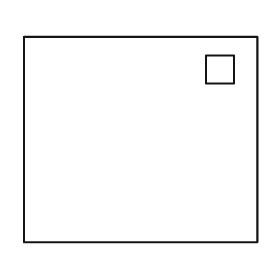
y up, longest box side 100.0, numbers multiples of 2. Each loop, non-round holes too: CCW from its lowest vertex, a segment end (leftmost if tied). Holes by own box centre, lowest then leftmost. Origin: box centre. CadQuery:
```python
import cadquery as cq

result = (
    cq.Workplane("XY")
    .moveTo(-50.0, -44.0)
    .lineTo(50.0, -44.0)
    .lineTo(50.0, 44.0)
    .lineTo(-50.0, 44.0)
    .close()
    .moveTo(28.0, 24.0)
    .lineTo(40.0, 24.0)
    .lineTo(40.0, 36.0)
    .lineTo(28.0, 36.0)
    .close()
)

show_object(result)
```